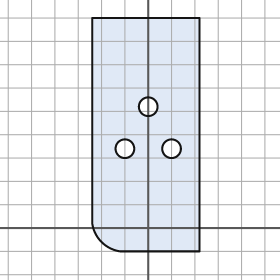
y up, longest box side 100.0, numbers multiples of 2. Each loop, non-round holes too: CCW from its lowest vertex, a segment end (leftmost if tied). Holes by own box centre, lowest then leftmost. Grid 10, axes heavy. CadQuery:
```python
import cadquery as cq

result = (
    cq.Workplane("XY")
    .moveTo(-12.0, -10.0)
    .lineTo(22.0, -10.0)
    .lineTo(22.0, 90.0)
    .lineTo(-24.0, 90.0)
    .lineTo(-24.0, 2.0)
    .threePointArc((-20.0, -6.0), (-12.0, -10.0))
    .close()
    .moveTo(-10.0, 34.0)
    .circle(4.0)
    .moveTo(10.0, 34.0)
    .circle(4.0)
    .moveTo(0.0, 52.0)
    .circle(4.0)
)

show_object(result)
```